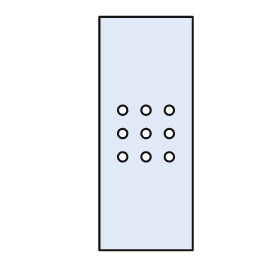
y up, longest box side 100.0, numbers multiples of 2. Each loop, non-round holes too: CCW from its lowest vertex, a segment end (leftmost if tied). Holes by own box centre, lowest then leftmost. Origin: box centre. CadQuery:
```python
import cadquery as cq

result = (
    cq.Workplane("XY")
    .moveTo(-20.0, -50.0)
    .lineTo(20.0, -50.0)
    .lineTo(20.0, 50.0)
    .lineTo(-20.0, 50.0)
    .close()
    .moveTo(-10.0, -10.0)
    .circle(2.0)
    .moveTo(0.0, -10.0)
    .circle(2.0)
    .moveTo(10.0, -10.0)
    .circle(2.0)
    .moveTo(-10.0, 0.0)
    .circle(2.0)
    .moveTo(0.0, 0.0)
    .circle(2.0)
    .moveTo(10.0, 0.0)
    .circle(2.0)
    .moveTo(-10.0, 10.0)
    .circle(2.0)
    .moveTo(0.0, 10.0)
    .circle(2.0)
    .moveTo(10.0, 10.0)
    .circle(2.0)
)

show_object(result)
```